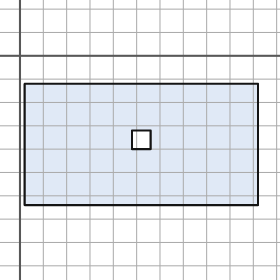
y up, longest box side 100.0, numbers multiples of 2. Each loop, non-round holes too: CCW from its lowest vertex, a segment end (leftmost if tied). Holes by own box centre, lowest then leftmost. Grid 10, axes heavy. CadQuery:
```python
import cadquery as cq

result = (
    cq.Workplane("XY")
    .moveTo(2.0, -64.0)
    .lineTo(102.0, -64.0)
    .lineTo(102.0, -12.0)
    .lineTo(2.0, -12.0)
    .close()
    .moveTo(48.0, -40.0)
    .lineTo(56.0, -40.0)
    .lineTo(56.0, -32.0)
    .lineTo(48.0, -32.0)
    .close()
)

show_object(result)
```